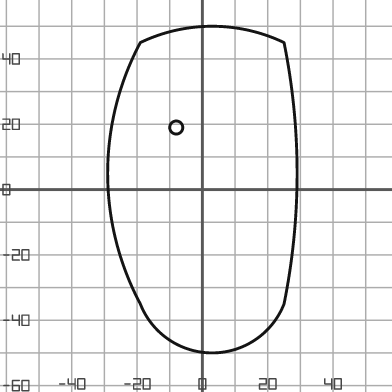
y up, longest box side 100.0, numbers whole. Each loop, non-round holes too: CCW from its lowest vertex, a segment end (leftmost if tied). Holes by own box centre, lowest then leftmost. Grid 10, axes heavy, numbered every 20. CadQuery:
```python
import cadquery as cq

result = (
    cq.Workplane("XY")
    .moveTo(-19.0, -35.0)
    .threePointArc((3.0, -50.0), (25.0, -35.0))
    .threePointArc((29.0, 5.0), (25.0, 45.0))
    .threePointArc((3.0, 50.0), (-19.0, 45.0))
    .threePointArc((-29.0, 5.0), (-19.0, -35.0))
    .close()
    .moveTo(-8.0, 19.0)
    .circle(2.0)
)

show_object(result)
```